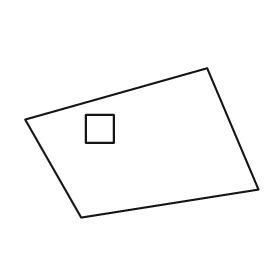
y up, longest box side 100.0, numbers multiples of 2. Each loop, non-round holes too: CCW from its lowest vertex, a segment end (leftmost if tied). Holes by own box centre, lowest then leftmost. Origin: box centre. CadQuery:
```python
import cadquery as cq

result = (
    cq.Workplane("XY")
    .moveTo(-26.0, -32.0)
    .lineTo(50.0, -20.0)
    .lineTo(28.0, 32.0)
    .lineTo(-50.0, 10.0)
    .close()
    .moveTo(-24.0, 0.0)
    .lineTo(-12.0, 0.0)
    .lineTo(-12.0, 12.0)
    .lineTo(-24.0, 12.0)
    .close()
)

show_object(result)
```